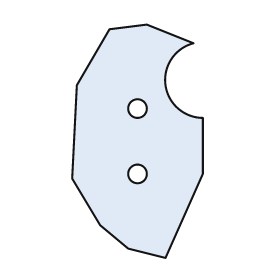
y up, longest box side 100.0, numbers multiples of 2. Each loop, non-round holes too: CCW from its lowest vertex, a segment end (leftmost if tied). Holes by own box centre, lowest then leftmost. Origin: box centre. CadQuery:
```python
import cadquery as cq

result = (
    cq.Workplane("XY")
    .moveTo(12.0, -50.0)
    .lineTo(28.0, -14.0)
    .lineTo(28.0, 10.0)
    .threePointArc((12.0, 24.0), (24.0, 42.0))
    .lineTo(4.0, 50.0)
    .lineTo(-12.0, 48.0)
    .lineTo(-26.0, 24.0)
    .lineTo(-28.0, -16.0)
    .lineTo(-16.0, -36.0)
    .lineTo(-4.0, -46.0)
    .close()
    .moveTo(0.0, -14.0)
    .circle(4.0)
    .moveTo(0.0, 14.0)
    .circle(4.0)
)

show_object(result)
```